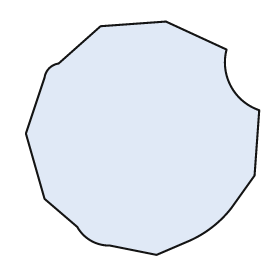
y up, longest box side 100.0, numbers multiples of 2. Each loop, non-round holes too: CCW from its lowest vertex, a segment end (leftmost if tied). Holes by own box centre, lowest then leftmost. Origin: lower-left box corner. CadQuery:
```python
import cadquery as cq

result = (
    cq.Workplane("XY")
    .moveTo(56.0, 0.0)
    .lineTo(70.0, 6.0)
    .threePointArc((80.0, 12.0), (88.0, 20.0))
    .lineTo(98.0, 34.0)
    .lineTo(100.0, 62.0)
    .threePointArc((88.0, 72.0), (86.0, 88.0))
    .lineTo(60.0, 100.0)
    .lineTo(32.0, 98.0)
    .lineTo(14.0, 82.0)
    .threePointArc((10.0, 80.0), (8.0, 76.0))
    .lineTo(0.0, 52.0)
    .lineTo(8.0, 24.0)
    .lineTo(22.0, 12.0)
    .threePointArc((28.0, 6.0), (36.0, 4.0))
    .close()
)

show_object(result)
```